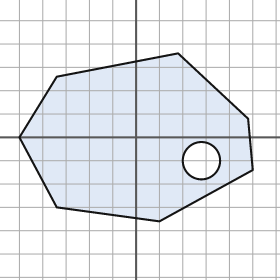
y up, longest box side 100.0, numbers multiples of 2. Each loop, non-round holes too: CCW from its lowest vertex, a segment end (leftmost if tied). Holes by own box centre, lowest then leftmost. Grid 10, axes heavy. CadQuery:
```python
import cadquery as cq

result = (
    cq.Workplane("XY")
    .moveTo(10.0, -36.0)
    .lineTo(50.0, -14.0)
    .lineTo(48.0, 8.0)
    .lineTo(18.0, 36.0)
    .lineTo(-34.0, 26.0)
    .lineTo(-50.0, 0.0)
    .lineTo(-34.0, -30.0)
    .close()
    .moveTo(28.0, -10.0)
    .circle(8.0)
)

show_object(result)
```